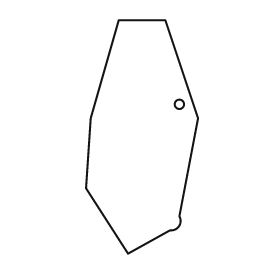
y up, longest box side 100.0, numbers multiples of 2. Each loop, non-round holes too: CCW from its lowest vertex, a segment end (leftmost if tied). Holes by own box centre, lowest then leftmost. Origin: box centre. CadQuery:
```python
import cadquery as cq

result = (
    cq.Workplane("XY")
    .moveTo(-6.0, -50.0)
    .lineTo(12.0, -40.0)
    .threePointArc((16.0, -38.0), (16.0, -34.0))
    .lineTo(24.0, 8.0)
    .lineTo(10.0, 50.0)
    .lineTo(-10.0, 50.0)
    .lineTo(-22.0, 8.0)
    .lineTo(-24.0, -22.0)
    .close()
    .moveTo(16.0, 14.0)
    .circle(2.0)
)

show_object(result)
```